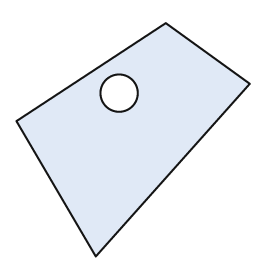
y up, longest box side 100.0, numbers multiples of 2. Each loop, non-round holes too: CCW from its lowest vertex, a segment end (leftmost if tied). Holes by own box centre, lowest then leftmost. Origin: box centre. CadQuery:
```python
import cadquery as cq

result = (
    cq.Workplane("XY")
    .moveTo(-16.0, -50.0)
    .lineTo(50.0, 24.0)
    .lineTo(14.0, 50.0)
    .lineTo(-50.0, 8.0)
    .close()
    .moveTo(-6.0, 20.0)
    .circle(8.0)
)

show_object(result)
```